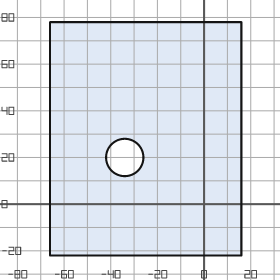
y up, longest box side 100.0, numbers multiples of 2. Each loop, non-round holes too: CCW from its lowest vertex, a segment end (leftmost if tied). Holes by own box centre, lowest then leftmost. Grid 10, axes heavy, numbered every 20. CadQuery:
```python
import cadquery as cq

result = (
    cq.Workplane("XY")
    .moveTo(-66.0, -22.0)
    .lineTo(16.0, -22.0)
    .lineTo(16.0, 78.0)
    .lineTo(-66.0, 78.0)
    .close()
    .moveTo(-34.0, 20.0)
    .circle(8.0)
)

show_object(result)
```